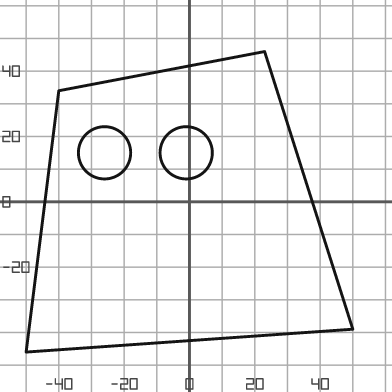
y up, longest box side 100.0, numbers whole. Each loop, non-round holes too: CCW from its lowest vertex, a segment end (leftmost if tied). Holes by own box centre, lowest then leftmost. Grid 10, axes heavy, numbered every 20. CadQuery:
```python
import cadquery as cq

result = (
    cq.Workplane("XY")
    .moveTo(-50.0, -46.0)
    .lineTo(50.0, -39.0)
    .lineTo(23.0, 46.0)
    .lineTo(-40.0, 34.0)
    .close()
    .moveTo(-26.0, 15.0)
    .circle(8.0)
    .moveTo(-1.0, 15.0)
    .circle(8.0)
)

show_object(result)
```